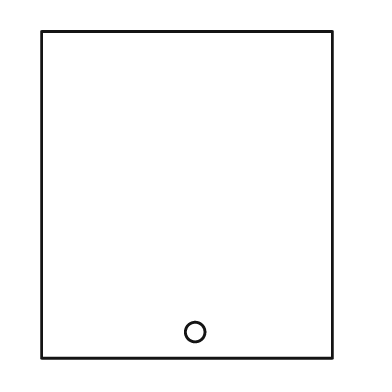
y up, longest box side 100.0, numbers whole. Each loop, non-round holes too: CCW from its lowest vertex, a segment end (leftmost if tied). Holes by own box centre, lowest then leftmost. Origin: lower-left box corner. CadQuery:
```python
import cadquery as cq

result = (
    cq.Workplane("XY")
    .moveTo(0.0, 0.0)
    .lineTo(89.0, 0.0)
    .lineTo(89.0, 100.0)
    .lineTo(0.0, 100.0)
    .close()
    .moveTo(47.0, 8.0)
    .circle(3.0)
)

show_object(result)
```